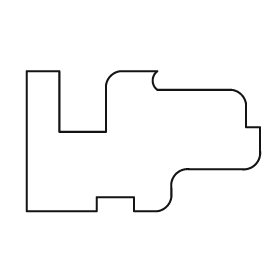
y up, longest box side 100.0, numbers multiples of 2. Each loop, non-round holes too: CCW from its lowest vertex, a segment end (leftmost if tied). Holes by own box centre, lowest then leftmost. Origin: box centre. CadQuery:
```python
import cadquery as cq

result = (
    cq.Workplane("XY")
    .moveTo(-50.0, -30.0)
    .lineTo(-20.0, -30.0)
    .lineTo(-20.0, -24.0)
    .lineTo(-4.0, -24.0)
    .lineTo(-4.0, -30.0)
    .lineTo(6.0, -30.0)
    .threePointArc((10.0, -28.0), (12.0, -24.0))
    .lineTo(12.0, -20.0)
    .threePointArc((14.0, -14.0), (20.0, -12.0))
    .lineTo(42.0, -12.0)
    .threePointArc((48.0, -10.0), (50.0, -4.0))
    .lineTo(50.0, 6.0)
    .lineTo(44.0, 6.0)
    .lineTo(44.0, 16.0)
    .threePointArc((42.0, 20.0), (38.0, 22.0))
    .lineTo(6.0, 22.0)
    .threePointArc((4.0, 26.0), (6.0, 30.0))
    .lineTo(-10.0, 30.0)
    .threePointArc((-14.0, 28.0), (-16.0, 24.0))
    .lineTo(-16.0, 4.0)
    .lineTo(-36.0, 4.0)
    .lineTo(-36.0, 30.0)
    .lineTo(-50.0, 30.0)
    .close()
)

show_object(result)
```